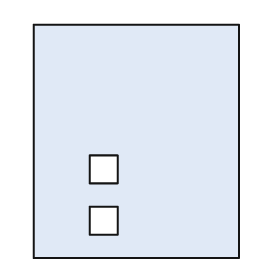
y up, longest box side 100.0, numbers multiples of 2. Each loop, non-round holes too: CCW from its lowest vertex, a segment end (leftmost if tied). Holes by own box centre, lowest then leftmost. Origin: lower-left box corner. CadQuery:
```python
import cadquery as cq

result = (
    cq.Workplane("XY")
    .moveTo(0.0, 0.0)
    .lineTo(88.0, 0.0)
    .lineTo(88.0, 100.0)
    .lineTo(0.0, 100.0)
    .close()
    .moveTo(24.0, 10.0)
    .lineTo(36.0, 10.0)
    .lineTo(36.0, 22.0)
    .lineTo(24.0, 22.0)
    .close()
    .moveTo(24.0, 32.0)
    .lineTo(36.0, 32.0)
    .lineTo(36.0, 44.0)
    .lineTo(24.0, 44.0)
    .close()
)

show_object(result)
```